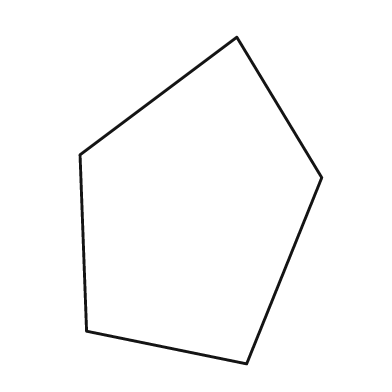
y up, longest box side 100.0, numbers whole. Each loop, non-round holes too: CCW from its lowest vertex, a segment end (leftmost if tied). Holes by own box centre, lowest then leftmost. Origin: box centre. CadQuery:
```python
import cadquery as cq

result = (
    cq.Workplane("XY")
    .moveTo(14.0, -50.0)
    .lineTo(37.0, 7.0)
    .lineTo(11.0, 50.0)
    .lineTo(-37.0, 14.0)
    .lineTo(-35.0, -40.0)
    .close()
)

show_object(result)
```